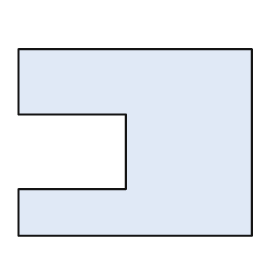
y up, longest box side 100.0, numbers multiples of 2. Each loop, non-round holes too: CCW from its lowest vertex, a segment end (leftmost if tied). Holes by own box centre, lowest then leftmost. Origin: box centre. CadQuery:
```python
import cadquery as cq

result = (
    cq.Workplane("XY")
    .moveTo(-50.0, -40.0)
    .lineTo(50.0, -40.0)
    .lineTo(50.0, 40.0)
    .lineTo(-50.0, 40.0)
    .lineTo(-50.0, 12.0)
    .lineTo(-4.0, 12.0)
    .lineTo(-4.0, -20.0)
    .lineTo(-50.0, -20.0)
    .close()
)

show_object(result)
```